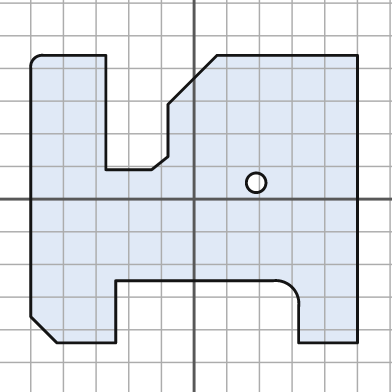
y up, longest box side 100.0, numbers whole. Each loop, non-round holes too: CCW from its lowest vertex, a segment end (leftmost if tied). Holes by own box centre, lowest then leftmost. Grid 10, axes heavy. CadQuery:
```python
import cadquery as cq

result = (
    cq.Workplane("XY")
    .moveTo(-42.0, -44.0)
    .lineTo(-24.0, -44.0)
    .lineTo(-24.0, -25.0)
    .lineTo(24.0, -25.0)
    .threePointArc((30.0, -27.0), (32.0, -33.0))
    .lineTo(32.0, -44.0)
    .lineTo(50.0, -44.0)
    .lineTo(50.0, 44.0)
    .lineTo(7.0, 44.0)
    .lineTo(-8.0, 29.0)
    .lineTo(-8.0, 13.0)
    .lineTo(-13.0, 9.0)
    .lineTo(-27.0, 9.0)
    .lineTo(-27.0, 44.0)
    .lineTo(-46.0, 44.0)
    .threePointArc((-49.0, 43.0), (-50.0, 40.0))
    .lineTo(-50.0, -36.0)
    .close()
    .moveTo(19.0, 5.0)
    .circle(3.0)
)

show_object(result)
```